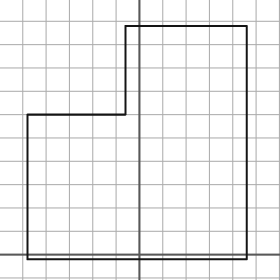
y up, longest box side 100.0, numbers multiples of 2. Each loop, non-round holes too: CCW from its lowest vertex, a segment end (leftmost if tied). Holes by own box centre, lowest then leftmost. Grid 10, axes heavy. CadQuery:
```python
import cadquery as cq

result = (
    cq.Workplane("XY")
    .moveTo(-48.0, -2.0)
    .lineTo(46.0, -2.0)
    .lineTo(46.0, 98.0)
    .lineTo(-6.0, 98.0)
    .lineTo(-6.0, 60.0)
    .lineTo(-48.0, 60.0)
    .close()
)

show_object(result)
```